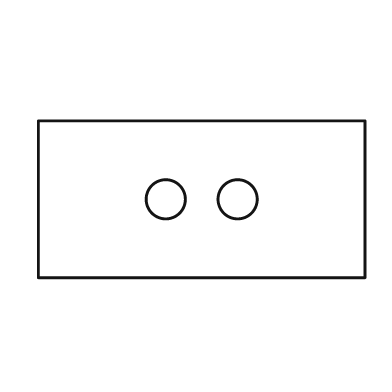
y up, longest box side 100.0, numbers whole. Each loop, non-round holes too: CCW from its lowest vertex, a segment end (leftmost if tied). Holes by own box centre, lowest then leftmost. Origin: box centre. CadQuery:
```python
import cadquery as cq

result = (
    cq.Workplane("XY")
    .moveTo(-50.0, -24.0)
    .lineTo(50.0, -24.0)
    .lineTo(50.0, 24.0)
    .lineTo(-50.0, 24.0)
    .close()
    .moveTo(-11.0, 0.0)
    .circle(6.0)
    .moveTo(11.0, 0.0)
    .circle(6.0)
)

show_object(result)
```